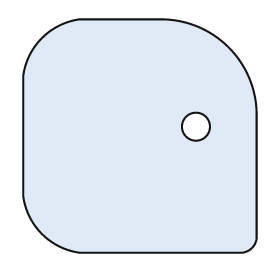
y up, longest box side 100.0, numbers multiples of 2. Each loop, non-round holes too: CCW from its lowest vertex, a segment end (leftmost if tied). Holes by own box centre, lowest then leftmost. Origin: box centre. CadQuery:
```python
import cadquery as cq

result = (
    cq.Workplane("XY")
    .moveTo(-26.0, -50.0)
    .lineTo(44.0, -50.0)
    .threePointArc((48.0, -48.0), (50.0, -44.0))
    .lineTo(50.0, 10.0)
    .threePointArc((38.0, 38.0), (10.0, 50.0))
    .lineTo(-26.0, 50.0)
    .threePointArc((-42.0, 42.0), (-50.0, 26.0))
    .lineTo(-50.0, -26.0)
    .threePointArc((-42.0, -42.0), (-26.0, -50.0))
    .close()
    .moveTo(24.0, 4.0)
    .circle(6.0)
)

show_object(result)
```